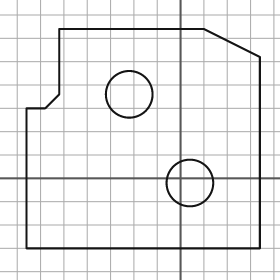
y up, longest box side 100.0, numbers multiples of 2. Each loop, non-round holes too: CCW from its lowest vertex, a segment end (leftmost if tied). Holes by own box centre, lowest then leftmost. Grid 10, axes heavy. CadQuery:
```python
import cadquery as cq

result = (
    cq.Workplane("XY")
    .moveTo(-66.0, -30.0)
    .lineTo(34.0, -30.0)
    .lineTo(34.0, 52.0)
    .lineTo(10.0, 64.0)
    .lineTo(-52.0, 64.0)
    .lineTo(-52.0, 36.0)
    .lineTo(-58.0, 30.0)
    .lineTo(-66.0, 30.0)
    .close()
    .moveTo(4.0, -2.0)
    .circle(10.0)
    .moveTo(-22.0, 36.0)
    .circle(10.0)
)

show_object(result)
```